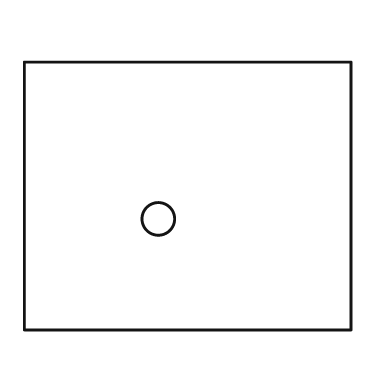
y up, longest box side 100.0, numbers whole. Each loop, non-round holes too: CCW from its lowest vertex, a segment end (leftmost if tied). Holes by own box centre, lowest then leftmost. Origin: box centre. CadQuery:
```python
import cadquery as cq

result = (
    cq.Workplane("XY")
    .moveTo(-50.0, -41.0)
    .lineTo(50.0, -41.0)
    .lineTo(50.0, 41.0)
    .lineTo(-50.0, 41.0)
    .close()
    .moveTo(-9.0, -7.0)
    .circle(5.0)
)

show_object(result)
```